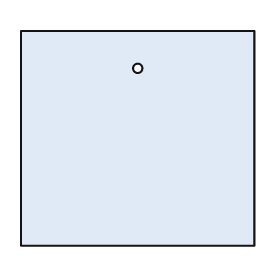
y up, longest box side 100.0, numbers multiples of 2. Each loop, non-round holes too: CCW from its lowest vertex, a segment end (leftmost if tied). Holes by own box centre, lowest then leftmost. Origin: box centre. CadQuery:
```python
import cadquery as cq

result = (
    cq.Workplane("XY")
    .moveTo(-50.0, -46.0)
    .lineTo(50.0, -46.0)
    .lineTo(50.0, 46.0)
    .lineTo(-50.0, 46.0)
    .close()
    .moveTo(0.0, 30.0)
    .circle(2.0)
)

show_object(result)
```